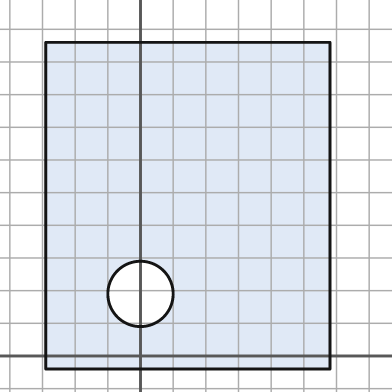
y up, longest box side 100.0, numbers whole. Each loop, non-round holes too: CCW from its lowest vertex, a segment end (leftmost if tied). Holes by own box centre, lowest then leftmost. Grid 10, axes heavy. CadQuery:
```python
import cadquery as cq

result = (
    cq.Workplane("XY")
    .moveTo(-29.0, -4.0)
    .lineTo(58.0, -4.0)
    .lineTo(58.0, 96.0)
    .lineTo(-29.0, 96.0)
    .close()
    .moveTo(0.0, 19.0)
    .circle(10.0)
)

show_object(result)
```